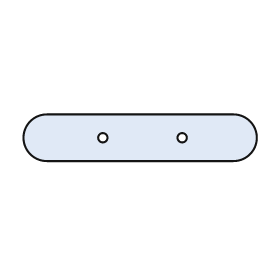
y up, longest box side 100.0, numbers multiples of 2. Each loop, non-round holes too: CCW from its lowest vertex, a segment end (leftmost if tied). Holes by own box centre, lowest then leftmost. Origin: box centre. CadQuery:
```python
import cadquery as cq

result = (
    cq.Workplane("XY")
    .moveTo(-40.0, -10.0)
    .lineTo(40.0, -10.0)
    .threePointArc((50.0, 0.0), (40.0, 10.0))
    .lineTo(-40.0, 10.0)
    .threePointArc((-50.0, 0.0), (-40.0, -10.0))
    .close()
    .moveTo(-16.0, 0.0)
    .circle(2.0)
    .moveTo(18.0, 0.0)
    .circle(2.0)
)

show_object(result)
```